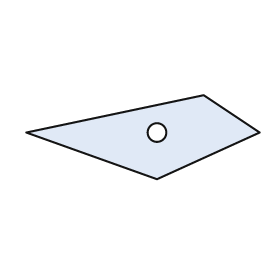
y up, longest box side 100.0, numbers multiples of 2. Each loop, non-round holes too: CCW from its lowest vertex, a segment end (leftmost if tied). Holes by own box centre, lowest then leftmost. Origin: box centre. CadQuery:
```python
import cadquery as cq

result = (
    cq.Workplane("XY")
    .moveTo(6.0, -18.0)
    .lineTo(50.0, 2.0)
    .lineTo(26.0, 18.0)
    .lineTo(-50.0, 2.0)
    .close()
    .moveTo(6.0, 2.0)
    .circle(4.0)
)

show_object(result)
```